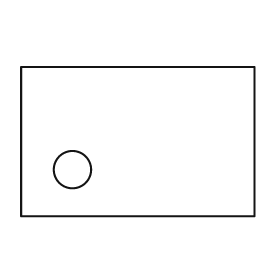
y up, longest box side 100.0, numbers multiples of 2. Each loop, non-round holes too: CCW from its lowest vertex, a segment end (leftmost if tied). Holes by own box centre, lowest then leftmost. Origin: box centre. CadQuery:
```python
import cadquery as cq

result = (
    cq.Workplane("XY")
    .moveTo(-50.0, -32.0)
    .lineTo(50.0, -32.0)
    .lineTo(50.0, 32.0)
    .lineTo(-50.0, 32.0)
    .close()
    .moveTo(-28.0, -12.0)
    .circle(8.0)
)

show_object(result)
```